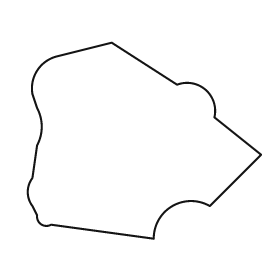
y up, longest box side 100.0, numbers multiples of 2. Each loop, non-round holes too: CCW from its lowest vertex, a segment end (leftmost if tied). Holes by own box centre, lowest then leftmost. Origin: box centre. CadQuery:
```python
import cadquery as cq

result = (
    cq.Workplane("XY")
    .moveTo(4.0, -42.0)
    .threePointArc((12.0, -28.0), (28.0, -28.0))
    .lineTo(50.0, -6.0)
    .lineTo(30.0, 10.0)
    .threePointArc((26.0, 22.0), (14.0, 24.0))
    .lineTo(-14.0, 42.0)
    .lineTo(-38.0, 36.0)
    .threePointArc((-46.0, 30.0), (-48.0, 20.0))
    .lineTo(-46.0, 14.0)
    .threePointArc((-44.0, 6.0), (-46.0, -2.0))
    .lineTo(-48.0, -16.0)
    .threePointArc((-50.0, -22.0), (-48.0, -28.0))
    .lineTo(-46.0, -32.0)
    .threePointArc((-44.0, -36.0), (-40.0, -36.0))
    .close()
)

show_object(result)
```